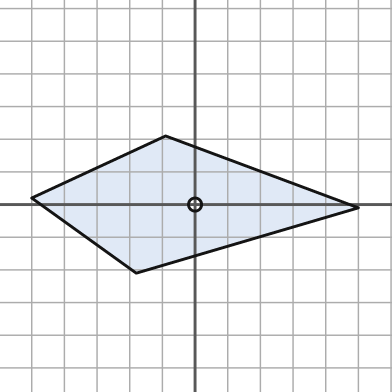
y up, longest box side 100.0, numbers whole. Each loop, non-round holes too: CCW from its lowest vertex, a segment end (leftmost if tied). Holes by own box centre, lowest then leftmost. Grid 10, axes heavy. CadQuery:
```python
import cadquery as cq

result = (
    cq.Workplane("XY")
    .moveTo(-18.0, -21.0)
    .lineTo(50.0, -1.0)
    .lineTo(-9.0, 21.0)
    .lineTo(-50.0, 2.0)
    .close()
    .moveTo(0.0, 0.0)
    .circle(2.0)
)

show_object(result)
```